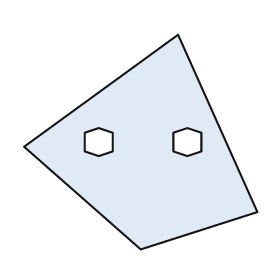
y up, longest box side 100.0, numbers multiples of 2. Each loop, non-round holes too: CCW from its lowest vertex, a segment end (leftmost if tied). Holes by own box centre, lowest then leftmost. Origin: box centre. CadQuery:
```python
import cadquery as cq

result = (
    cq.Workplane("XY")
    .moveTo(0.0, -46.0)
    .lineTo(50.0, -30.0)
    .lineTo(16.0, 46.0)
    .lineTo(-50.0, -2.0)
    .close()
    .moveTo(-18.0, -6.0)
    .lineTo(-12.0, -4.0)
    .lineTo(-12.0, 4.0)
    .lineTo(-18.0, 6.0)
    .lineTo(-24.0, 4.0)
    .lineTo(-24.0, -4.0)
    .close()
    .moveTo(20.0, -6.0)
    .lineTo(26.0, -4.0)
    .lineTo(26.0, 4.0)
    .lineTo(20.0, 6.0)
    .lineTo(14.0, 4.0)
    .lineTo(14.0, -4.0)
    .close()
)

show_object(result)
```